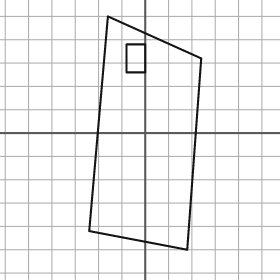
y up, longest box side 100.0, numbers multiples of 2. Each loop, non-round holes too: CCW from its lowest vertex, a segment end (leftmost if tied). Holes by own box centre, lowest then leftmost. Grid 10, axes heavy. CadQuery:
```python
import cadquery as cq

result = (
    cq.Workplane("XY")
    .moveTo(18.0, -50.0)
    .lineTo(24.0, 32.0)
    .lineTo(-16.0, 50.0)
    .lineTo(-24.0, -42.0)
    .close()
    .moveTo(-8.0, 26.0)
    .lineTo(0.0, 26.0)
    .lineTo(0.0, 38.0)
    .lineTo(-8.0, 38.0)
    .close()
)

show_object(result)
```